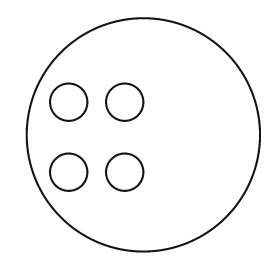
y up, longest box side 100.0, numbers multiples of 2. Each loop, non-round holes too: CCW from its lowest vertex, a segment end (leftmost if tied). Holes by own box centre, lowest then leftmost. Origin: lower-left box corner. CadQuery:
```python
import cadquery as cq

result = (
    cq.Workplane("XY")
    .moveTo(50.0, 50.0)
    .circle(50.0)
    .moveTo(18.0, 34.0)
    .circle(8.0)
    .moveTo(42.0, 34.0)
    .circle(8.0)
    .moveTo(18.0, 64.0)
    .circle(8.0)
    .moveTo(42.0, 64.0)
    .circle(8.0)
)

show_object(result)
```